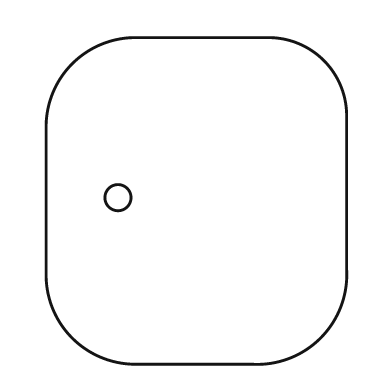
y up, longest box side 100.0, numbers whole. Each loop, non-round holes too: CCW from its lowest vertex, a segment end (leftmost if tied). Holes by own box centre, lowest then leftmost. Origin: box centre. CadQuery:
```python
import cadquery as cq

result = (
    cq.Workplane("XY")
    .moveTo(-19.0, -50.0)
    .lineTo(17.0, -50.0)
    .threePointArc((38.0, -42.0), (46.0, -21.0))
    .lineTo(46.0, 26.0)
    .threePointArc((39.0, 43.0), (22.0, 50.0))
    .lineTo(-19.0, 50.0)
    .threePointArc((-38.0, 42.0), (-46.0, 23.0))
    .lineTo(-46.0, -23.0)
    .threePointArc((-38.0, -42.0), (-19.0, -50.0))
    .close()
    .moveTo(-24.0, 1.0)
    .circle(4.0)
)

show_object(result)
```